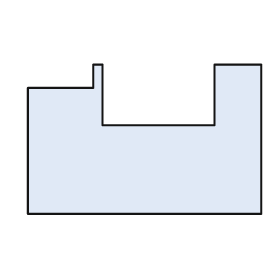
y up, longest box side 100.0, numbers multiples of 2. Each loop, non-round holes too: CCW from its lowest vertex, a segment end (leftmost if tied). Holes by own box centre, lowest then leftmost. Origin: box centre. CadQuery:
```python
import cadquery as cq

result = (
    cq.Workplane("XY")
    .moveTo(-50.0, -32.0)
    .lineTo(50.0, -32.0)
    .lineTo(50.0, 32.0)
    .lineTo(30.0, 32.0)
    .lineTo(30.0, 6.0)
    .lineTo(-18.0, 6.0)
    .lineTo(-18.0, 32.0)
    .lineTo(-22.0, 32.0)
    .lineTo(-22.0, 22.0)
    .lineTo(-50.0, 22.0)
    .close()
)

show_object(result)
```